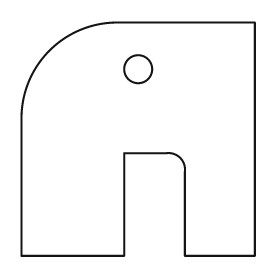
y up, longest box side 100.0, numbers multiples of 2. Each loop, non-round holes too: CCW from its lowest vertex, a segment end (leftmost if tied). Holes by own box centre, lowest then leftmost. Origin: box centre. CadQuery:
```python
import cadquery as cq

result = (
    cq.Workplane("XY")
    .moveTo(-50.0, -50.0)
    .lineTo(-6.0, -50.0)
    .lineTo(-6.0, -6.0)
    .lineTo(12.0, -6.0)
    .threePointArc((18.0, -8.0), (20.0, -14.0))
    .lineTo(20.0, -50.0)
    .lineTo(50.0, -50.0)
    .lineTo(50.0, 50.0)
    .lineTo(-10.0, 50.0)
    .threePointArc((-38.0, 38.0), (-50.0, 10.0))
    .close()
    .moveTo(0.0, 30.0)
    .circle(6.0)
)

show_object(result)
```